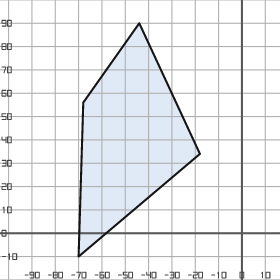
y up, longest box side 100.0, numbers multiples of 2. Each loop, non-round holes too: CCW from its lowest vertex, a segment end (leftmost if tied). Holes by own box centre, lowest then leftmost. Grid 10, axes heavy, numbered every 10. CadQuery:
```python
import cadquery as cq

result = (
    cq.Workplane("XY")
    .moveTo(-70.0, -10.0)
    .lineTo(-18.0, 34.0)
    .lineTo(-44.0, 90.0)
    .lineTo(-68.0, 56.0)
    .close()
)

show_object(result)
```